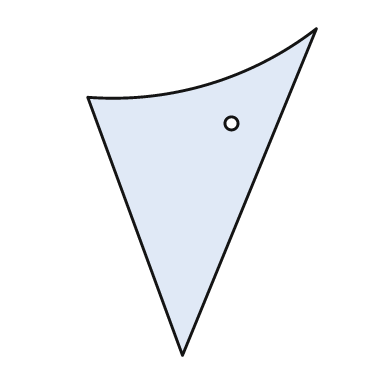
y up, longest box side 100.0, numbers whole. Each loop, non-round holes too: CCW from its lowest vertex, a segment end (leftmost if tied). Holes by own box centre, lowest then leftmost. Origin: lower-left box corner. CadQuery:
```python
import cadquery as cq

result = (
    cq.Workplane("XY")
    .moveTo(29.0, 0.0)
    .lineTo(70.0, 100.0)
    .threePointArc((37.0, 83.0), (0.0, 79.0))
    .close()
    .moveTo(44.0, 71.0)
    .circle(2.0)
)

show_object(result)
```